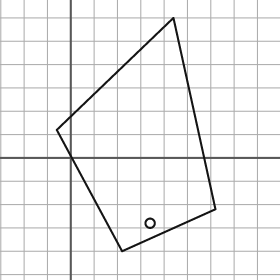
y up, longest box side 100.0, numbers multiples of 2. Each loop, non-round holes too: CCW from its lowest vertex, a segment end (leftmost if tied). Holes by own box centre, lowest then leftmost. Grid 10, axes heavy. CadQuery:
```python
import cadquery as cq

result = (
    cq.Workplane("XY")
    .moveTo(22.0, -40.0)
    .lineTo(62.0, -22.0)
    .lineTo(44.0, 60.0)
    .lineTo(-6.0, 12.0)
    .close()
    .moveTo(34.0, -28.0)
    .circle(2.0)
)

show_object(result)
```